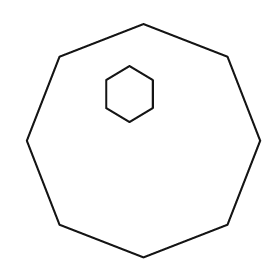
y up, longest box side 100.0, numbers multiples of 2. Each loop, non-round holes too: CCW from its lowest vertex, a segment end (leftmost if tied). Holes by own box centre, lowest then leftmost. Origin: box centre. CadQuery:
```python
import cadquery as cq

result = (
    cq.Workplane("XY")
    .moveTo(0.0, -50.0)
    .lineTo(36.0, -36.0)
    .lineTo(50.0, 0.0)
    .lineTo(36.0, 36.0)
    .lineTo(0.0, 50.0)
    .lineTo(-36.0, 36.0)
    .lineTo(-50.0, 0.0)
    .lineTo(-36.0, -36.0)
    .close()
    .moveTo(-6.0, 8.0)
    .lineTo(4.0, 14.0)
    .lineTo(4.0, 26.0)
    .lineTo(-6.0, 32.0)
    .lineTo(-16.0, 26.0)
    .lineTo(-16.0, 14.0)
    .close()
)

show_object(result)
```